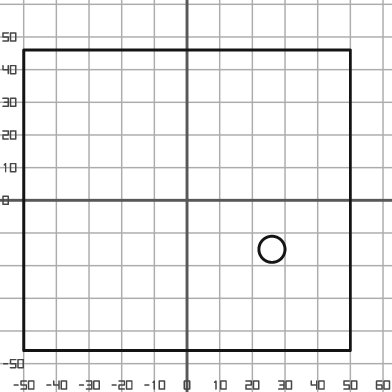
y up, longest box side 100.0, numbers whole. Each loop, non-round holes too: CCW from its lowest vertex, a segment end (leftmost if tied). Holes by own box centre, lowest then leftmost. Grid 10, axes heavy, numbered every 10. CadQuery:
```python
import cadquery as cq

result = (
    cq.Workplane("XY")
    .moveTo(-50.0, -46.0)
    .lineTo(50.0, -46.0)
    .lineTo(50.0, 46.0)
    .lineTo(-50.0, 46.0)
    .close()
    .moveTo(26.0, -15.0)
    .circle(4.0)
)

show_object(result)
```